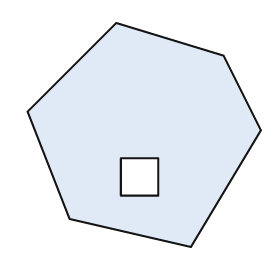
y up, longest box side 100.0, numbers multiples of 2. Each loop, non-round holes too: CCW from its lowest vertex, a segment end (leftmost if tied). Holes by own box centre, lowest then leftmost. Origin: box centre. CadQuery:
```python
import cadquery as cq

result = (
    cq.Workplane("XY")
    .moveTo(20.0, -48.0)
    .lineTo(50.0, 2.0)
    .lineTo(34.0, 34.0)
    .lineTo(-12.0, 48.0)
    .lineTo(-50.0, 10.0)
    .lineTo(-32.0, -36.0)
    .close()
    .moveTo(-10.0, -26.0)
    .lineTo(6.0, -26.0)
    .lineTo(6.0, -10.0)
    .lineTo(-10.0, -10.0)
    .close()
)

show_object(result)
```